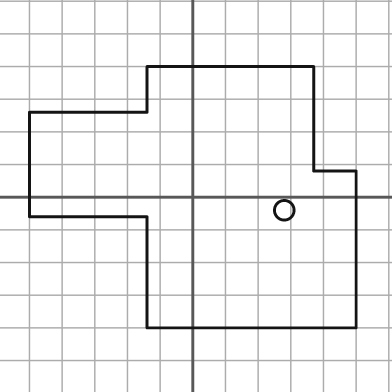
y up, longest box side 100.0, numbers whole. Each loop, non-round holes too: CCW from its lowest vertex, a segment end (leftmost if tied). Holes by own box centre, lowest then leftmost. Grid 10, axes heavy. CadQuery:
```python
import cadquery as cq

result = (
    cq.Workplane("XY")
    .moveTo(-14.0, -40.0)
    .lineTo(50.0, -40.0)
    .lineTo(50.0, 8.0)
    .lineTo(37.0, 8.0)
    .lineTo(37.0, 40.0)
    .lineTo(-14.0, 40.0)
    .lineTo(-14.0, 26.0)
    .lineTo(-50.0, 26.0)
    .lineTo(-50.0, -6.0)
    .lineTo(-14.0, -6.0)
    .close()
    .moveTo(28.0, -4.0)
    .circle(3.0)
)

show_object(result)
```